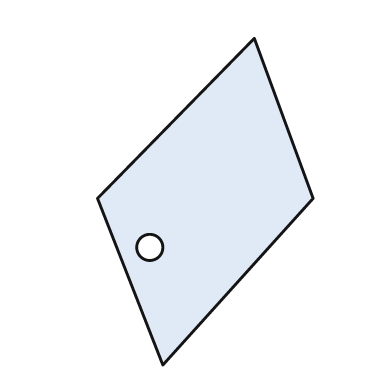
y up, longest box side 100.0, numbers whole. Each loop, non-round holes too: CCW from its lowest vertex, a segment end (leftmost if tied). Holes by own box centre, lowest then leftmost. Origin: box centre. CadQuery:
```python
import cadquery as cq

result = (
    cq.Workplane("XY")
    .moveTo(-13.0, -50.0)
    .lineTo(33.0, 1.0)
    .lineTo(15.0, 50.0)
    .lineTo(-33.0, 1.0)
    .close()
    .moveTo(-17.0, -14.0)
    .circle(4.0)
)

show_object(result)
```